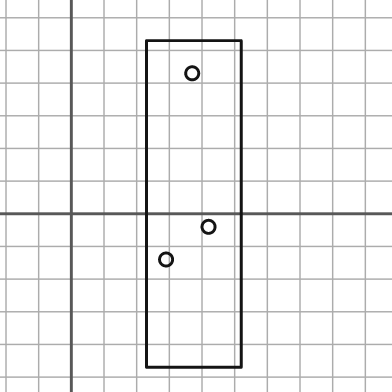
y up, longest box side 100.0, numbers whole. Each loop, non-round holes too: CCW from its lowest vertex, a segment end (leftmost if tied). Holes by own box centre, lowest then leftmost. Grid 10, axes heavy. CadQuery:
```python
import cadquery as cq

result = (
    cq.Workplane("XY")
    .moveTo(23.0, -47.0)
    .lineTo(52.0, -47.0)
    .lineTo(52.0, 53.0)
    .lineTo(23.0, 53.0)
    .close()
    .moveTo(29.0, -14.0)
    .circle(2.0)
    .moveTo(42.0, -4.0)
    .circle(2.0)
    .moveTo(37.0, 43.0)
    .circle(2.0)
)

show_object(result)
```